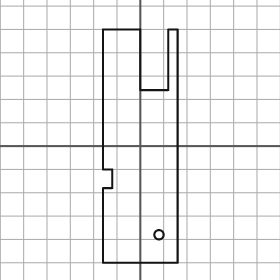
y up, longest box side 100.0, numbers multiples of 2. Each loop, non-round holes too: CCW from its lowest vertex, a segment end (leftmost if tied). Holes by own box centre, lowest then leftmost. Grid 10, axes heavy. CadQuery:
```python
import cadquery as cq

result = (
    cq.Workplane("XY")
    .moveTo(-16.0, -50.0)
    .lineTo(16.0, -50.0)
    .lineTo(16.0, 50.0)
    .lineTo(12.0, 50.0)
    .lineTo(12.0, 24.0)
    .lineTo(0.0, 24.0)
    .lineTo(0.0, 50.0)
    .lineTo(-16.0, 50.0)
    .lineTo(-16.0, -10.0)
    .lineTo(-12.0, -10.0)
    .lineTo(-12.0, -18.0)
    .lineTo(-16.0, -18.0)
    .close()
    .moveTo(8.0, -38.0)
    .circle(2.0)
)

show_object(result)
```